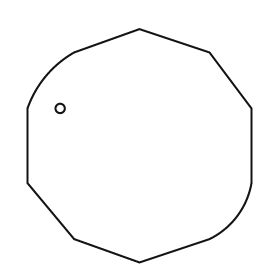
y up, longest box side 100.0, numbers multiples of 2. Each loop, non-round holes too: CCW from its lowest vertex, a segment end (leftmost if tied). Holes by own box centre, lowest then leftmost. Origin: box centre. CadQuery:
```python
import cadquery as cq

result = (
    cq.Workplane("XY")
    .moveTo(0.0, -50.0)
    .lineTo(30.0, -40.0)
    .threePointArc((42.0, -30.0), (48.0, -16.0))
    .lineTo(48.0, 16.0)
    .lineTo(30.0, 40.0)
    .lineTo(0.0, 50.0)
    .lineTo(-28.0, 40.0)
    .threePointArc((-40.0, 30.0), (-48.0, 16.0))
    .lineTo(-48.0, -16.0)
    .lineTo(-28.0, -40.0)
    .close()
    .moveTo(-34.0, 16.0)
    .circle(2.0)
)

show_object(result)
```